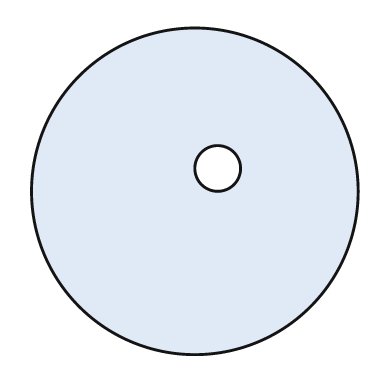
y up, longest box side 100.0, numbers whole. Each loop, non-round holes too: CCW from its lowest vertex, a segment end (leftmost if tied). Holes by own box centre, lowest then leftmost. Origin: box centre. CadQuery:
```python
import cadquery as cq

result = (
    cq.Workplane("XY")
    .moveTo(0.0, 0.0)
    .circle(50.0)
    .moveTo(7.0, 7.0)
    .circle(7.0)
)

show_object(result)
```